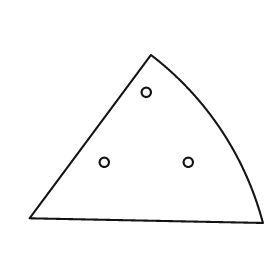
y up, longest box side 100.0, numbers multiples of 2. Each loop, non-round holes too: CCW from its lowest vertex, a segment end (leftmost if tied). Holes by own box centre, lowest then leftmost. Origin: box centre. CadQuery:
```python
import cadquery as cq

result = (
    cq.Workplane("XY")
    .moveTo(50.0, -36.0)
    .threePointArc((32.0, 4.0), (2.0, 36.0))
    .lineTo(-50.0, -34.0)
    .close()
    .moveTo(-18.0, -10.0)
    .circle(2.0)
    .moveTo(18.0, -10.0)
    .circle(2.0)
    .moveTo(0.0, 20.0)
    .circle(2.0)
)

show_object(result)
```